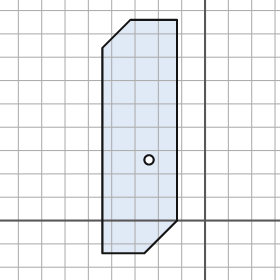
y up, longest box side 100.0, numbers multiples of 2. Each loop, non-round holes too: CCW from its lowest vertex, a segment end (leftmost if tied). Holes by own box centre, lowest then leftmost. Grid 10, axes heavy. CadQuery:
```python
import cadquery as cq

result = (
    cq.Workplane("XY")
    .moveTo(-44.0, -14.0)
    .lineTo(-26.0, -14.0)
    .lineTo(-12.0, 0.0)
    .lineTo(-12.0, 86.0)
    .lineTo(-32.0, 86.0)
    .lineTo(-44.0, 74.0)
    .close()
    .moveTo(-24.0, 26.0)
    .circle(2.0)
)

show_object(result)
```